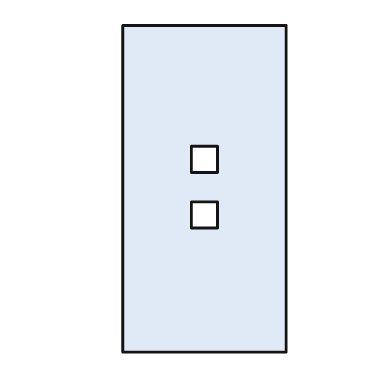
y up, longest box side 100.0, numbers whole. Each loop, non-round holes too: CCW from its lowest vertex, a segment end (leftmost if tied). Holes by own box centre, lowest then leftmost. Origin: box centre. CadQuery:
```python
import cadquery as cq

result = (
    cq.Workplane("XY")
    .moveTo(-25.0, -50.0)
    .lineTo(25.0, -50.0)
    .lineTo(25.0, 50.0)
    .lineTo(-25.0, 50.0)
    .close()
    .moveTo(-4.0, -12.0)
    .lineTo(4.0, -12.0)
    .lineTo(4.0, -4.0)
    .lineTo(-4.0, -4.0)
    .close()
    .moveTo(-4.0, 5.0)
    .lineTo(4.0, 5.0)
    .lineTo(4.0, 13.0)
    .lineTo(-4.0, 13.0)
    .close()
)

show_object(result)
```